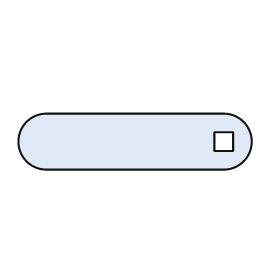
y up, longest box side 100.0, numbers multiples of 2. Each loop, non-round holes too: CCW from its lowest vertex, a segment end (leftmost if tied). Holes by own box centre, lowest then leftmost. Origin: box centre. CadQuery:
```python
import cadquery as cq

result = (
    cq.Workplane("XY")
    .moveTo(-38.0, -12.0)
    .lineTo(38.0, -12.0)
    .threePointArc((50.0, 0.0), (38.0, 12.0))
    .lineTo(-38.0, 12.0)
    .threePointArc((-50.0, 0.0), (-38.0, -12.0))
    .close()
    .moveTo(34.0, -4.0)
    .lineTo(42.0, -4.0)
    .lineTo(42.0, 4.0)
    .lineTo(34.0, 4.0)
    .close()
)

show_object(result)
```